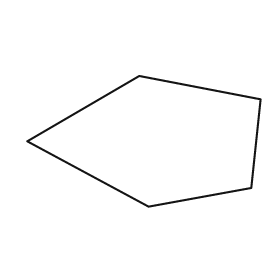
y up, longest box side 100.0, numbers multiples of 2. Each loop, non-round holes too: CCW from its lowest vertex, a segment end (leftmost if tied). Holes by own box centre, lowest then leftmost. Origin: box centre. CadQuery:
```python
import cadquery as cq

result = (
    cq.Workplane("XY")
    .moveTo(2.0, -28.0)
    .lineTo(46.0, -20.0)
    .lineTo(50.0, 18.0)
    .lineTo(-2.0, 28.0)
    .lineTo(-50.0, 0.0)
    .close()
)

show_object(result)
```